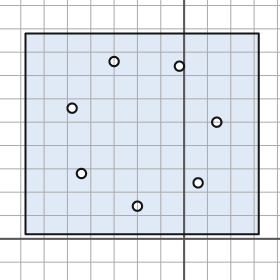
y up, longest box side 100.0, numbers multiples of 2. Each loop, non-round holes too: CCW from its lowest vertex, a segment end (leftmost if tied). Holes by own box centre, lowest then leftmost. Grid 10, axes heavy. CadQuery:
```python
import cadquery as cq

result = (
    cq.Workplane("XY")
    .moveTo(-68.0, 2.0)
    .lineTo(32.0, 2.0)
    .lineTo(32.0, 88.0)
    .lineTo(-68.0, 88.0)
    .close()
    .moveTo(-20.0, 14.0)
    .circle(2.0)
    .moveTo(6.0, 24.0)
    .circle(2.0)
    .moveTo(-44.0, 28.0)
    .circle(2.0)
    .moveTo(14.0, 50.0)
    .circle(2.0)
    .moveTo(-48.0, 56.0)
    .circle(2.0)
    .moveTo(-2.0, 74.0)
    .circle(2.0)
    .moveTo(-30.0, 76.0)
    .circle(2.0)
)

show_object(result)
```